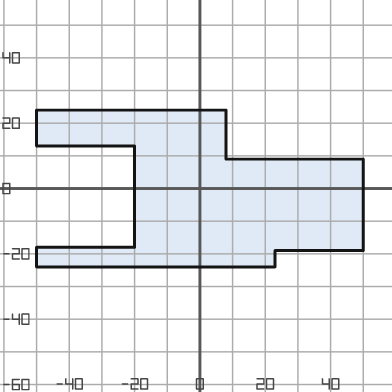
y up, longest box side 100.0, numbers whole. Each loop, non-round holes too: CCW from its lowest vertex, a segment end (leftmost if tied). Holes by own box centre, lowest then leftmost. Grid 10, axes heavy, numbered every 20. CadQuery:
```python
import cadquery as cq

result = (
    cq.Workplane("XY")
    .moveTo(-50.0, -24.0)
    .lineTo(23.0, -24.0)
    .lineTo(23.0, -19.0)
    .lineTo(50.0, -19.0)
    .lineTo(50.0, 9.0)
    .lineTo(8.0, 9.0)
    .lineTo(8.0, 24.0)
    .lineTo(-50.0, 24.0)
    .lineTo(-50.0, 13.0)
    .lineTo(-20.0, 13.0)
    .lineTo(-20.0, -18.0)
    .lineTo(-50.0, -18.0)
    .close()
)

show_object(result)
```